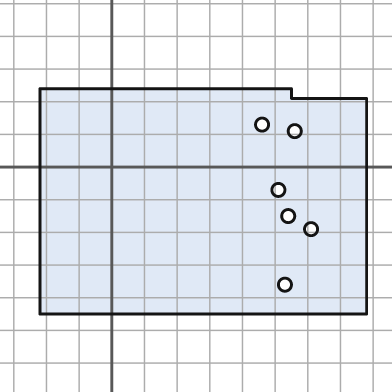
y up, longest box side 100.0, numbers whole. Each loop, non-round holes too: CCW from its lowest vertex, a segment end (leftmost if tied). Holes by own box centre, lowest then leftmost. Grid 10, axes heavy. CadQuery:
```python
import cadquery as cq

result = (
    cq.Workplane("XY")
    .moveTo(-22.0, -45.0)
    .lineTo(78.0, -45.0)
    .lineTo(78.0, 21.0)
    .lineTo(55.0, 21.0)
    .lineTo(55.0, 24.0)
    .lineTo(-22.0, 24.0)
    .close()
    .moveTo(53.0, -36.0)
    .circle(2.0)
    .moveTo(61.0, -19.0)
    .circle(2.0)
    .moveTo(54.0, -15.0)
    .circle(2.0)
    .moveTo(51.0, -7.0)
    .circle(2.0)
    .moveTo(56.0, 11.0)
    .circle(2.0)
    .moveTo(46.0, 13.0)
    .circle(2.0)
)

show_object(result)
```